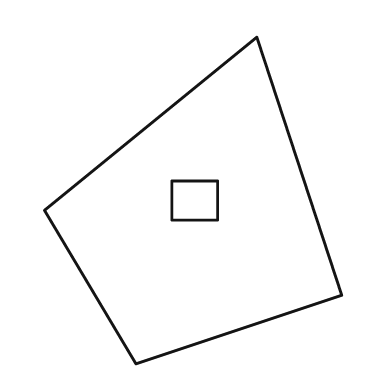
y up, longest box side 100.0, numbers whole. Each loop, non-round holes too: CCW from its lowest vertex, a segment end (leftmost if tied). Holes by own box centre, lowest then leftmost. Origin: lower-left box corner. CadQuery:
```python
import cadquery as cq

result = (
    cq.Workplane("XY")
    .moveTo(28.0, 0.0)
    .lineTo(91.0, 21.0)
    .lineTo(65.0, 100.0)
    .lineTo(0.0, 47.0)
    .close()
    .moveTo(39.0, 44.0)
    .lineTo(53.0, 44.0)
    .lineTo(53.0, 56.0)
    .lineTo(39.0, 56.0)
    .close()
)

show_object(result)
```